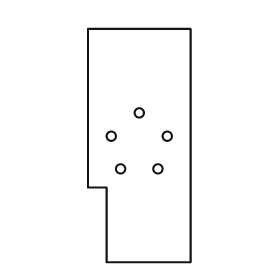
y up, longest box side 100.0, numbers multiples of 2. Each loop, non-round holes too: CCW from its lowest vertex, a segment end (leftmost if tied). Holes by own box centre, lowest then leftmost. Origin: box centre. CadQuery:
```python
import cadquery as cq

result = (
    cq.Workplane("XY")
    .moveTo(-14.0, -50.0)
    .lineTo(22.0, -50.0)
    .lineTo(22.0, 50.0)
    .lineTo(-22.0, 50.0)
    .lineTo(-22.0, -18.0)
    .lineTo(-14.0, -18.0)
    .close()
    .moveTo(-8.0, -10.0)
    .circle(2.0)
    .moveTo(8.0, -10.0)
    .circle(2.0)
    .moveTo(-12.0, 4.0)
    .circle(2.0)
    .moveTo(12.0, 4.0)
    .circle(2.0)
    .moveTo(0.0, 14.0)
    .circle(2.0)
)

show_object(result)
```